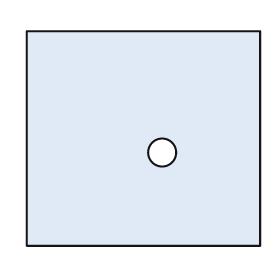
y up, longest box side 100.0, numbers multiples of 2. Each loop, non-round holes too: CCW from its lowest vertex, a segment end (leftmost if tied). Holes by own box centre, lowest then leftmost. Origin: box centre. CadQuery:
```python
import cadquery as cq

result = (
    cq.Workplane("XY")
    .moveTo(-50.0, -46.0)
    .lineTo(50.0, -46.0)
    .lineTo(50.0, 46.0)
    .lineTo(-50.0, 46.0)
    .close()
    .moveTo(8.0, -6.0)
    .circle(6.0)
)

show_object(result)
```